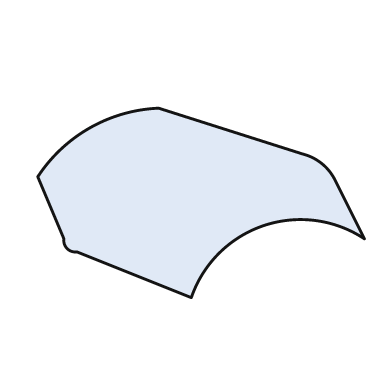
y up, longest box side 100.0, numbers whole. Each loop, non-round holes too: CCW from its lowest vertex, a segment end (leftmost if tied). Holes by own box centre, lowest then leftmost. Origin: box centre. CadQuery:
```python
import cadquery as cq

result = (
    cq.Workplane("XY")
    .moveTo(-3.0, -29.0)
    .threePointArc((19.0, -7.0), (50.0, -11.0))
    .lineTo(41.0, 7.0)
    .threePointArc((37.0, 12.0), (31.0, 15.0))
    .lineTo(-13.0, 29.0)
    .threePointArc((-34.0, 23.0), (-50.0, 8.0))
    .lineTo(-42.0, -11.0)
    .threePointArc((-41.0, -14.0), (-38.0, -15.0))
    .close()
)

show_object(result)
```